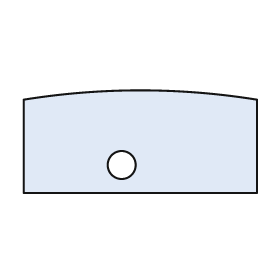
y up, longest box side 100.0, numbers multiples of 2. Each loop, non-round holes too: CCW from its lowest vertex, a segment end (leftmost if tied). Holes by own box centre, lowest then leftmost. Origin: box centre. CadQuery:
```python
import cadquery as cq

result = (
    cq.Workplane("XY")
    .moveTo(-50.0, -22.0)
    .lineTo(50.0, -22.0)
    .lineTo(50.0, 18.0)
    .threePointArc((0.0, 22.0), (-50.0, 18.0))
    .close()
    .moveTo(-8.0, -10.0)
    .circle(6.0)
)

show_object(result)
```